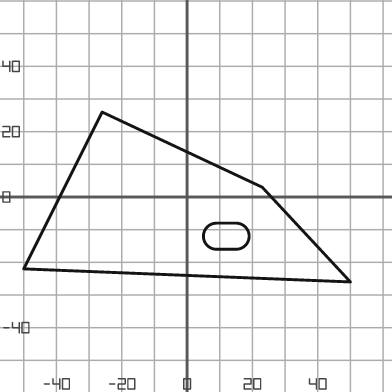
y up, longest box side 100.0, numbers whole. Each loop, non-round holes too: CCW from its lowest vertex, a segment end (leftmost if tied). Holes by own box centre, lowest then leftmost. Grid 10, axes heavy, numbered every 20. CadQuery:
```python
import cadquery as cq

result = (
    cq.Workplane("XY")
    .moveTo(50.0, -26.0)
    .lineTo(23.0, 3.0)
    .lineTo(-26.0, 26.0)
    .lineTo(-50.0, -22.0)
    .close()
    .moveTo(9.0, -16.0)
    .lineTo(15.0, -16.0)
    .threePointArc((19.0, -12.0), (15.0, -8.0))
    .lineTo(9.0, -8.0)
    .threePointArc((5.0, -12.0), (9.0, -16.0))
    .close()
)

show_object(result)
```